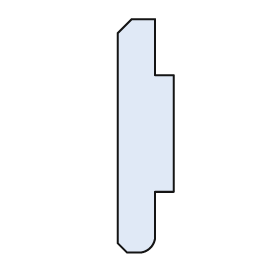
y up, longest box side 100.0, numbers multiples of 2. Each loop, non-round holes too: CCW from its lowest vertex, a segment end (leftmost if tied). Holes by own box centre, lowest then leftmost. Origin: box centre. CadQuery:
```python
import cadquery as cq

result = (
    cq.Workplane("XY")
    .moveTo(-8.0, -50.0)
    .lineTo(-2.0, -50.0)
    .threePointArc((2.0, -48.0), (4.0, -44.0))
    .lineTo(4.0, -24.0)
    .lineTo(12.0, -24.0)
    .lineTo(12.0, 26.0)
    .lineTo(4.0, 26.0)
    .lineTo(4.0, 50.0)
    .lineTo(-6.0, 50.0)
    .lineTo(-12.0, 44.0)
    .lineTo(-12.0, -46.0)
    .close()
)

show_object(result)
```